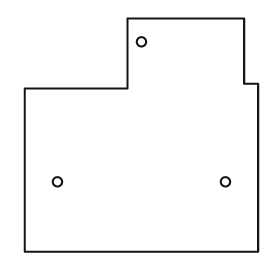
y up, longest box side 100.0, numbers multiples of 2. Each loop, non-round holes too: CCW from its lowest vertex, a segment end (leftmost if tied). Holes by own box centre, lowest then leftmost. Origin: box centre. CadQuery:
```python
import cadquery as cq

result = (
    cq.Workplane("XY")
    .moveTo(-50.0, -50.0)
    .lineTo(50.0, -50.0)
    .lineTo(50.0, 22.0)
    .lineTo(44.0, 22.0)
    .lineTo(44.0, 50.0)
    .lineTo(-6.0, 50.0)
    .lineTo(-6.0, 20.0)
    .lineTo(-50.0, 20.0)
    .close()
    .moveTo(-36.0, -20.0)
    .circle(2.0)
    .moveTo(36.0, -20.0)
    .circle(2.0)
    .moveTo(0.0, 40.0)
    .circle(2.0)
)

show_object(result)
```